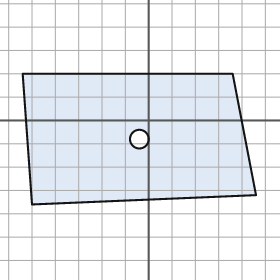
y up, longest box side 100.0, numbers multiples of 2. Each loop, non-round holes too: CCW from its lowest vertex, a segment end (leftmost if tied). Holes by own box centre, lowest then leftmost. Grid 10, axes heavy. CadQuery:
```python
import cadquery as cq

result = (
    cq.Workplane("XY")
    .moveTo(-50.0, -36.0)
    .lineTo(46.0, -32.0)
    .lineTo(36.0, 20.0)
    .lineTo(-54.0, 20.0)
    .close()
    .moveTo(-4.0, -8.0)
    .circle(4.0)
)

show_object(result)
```